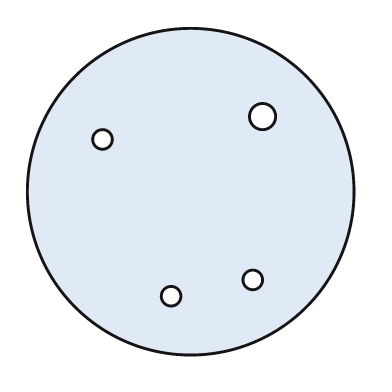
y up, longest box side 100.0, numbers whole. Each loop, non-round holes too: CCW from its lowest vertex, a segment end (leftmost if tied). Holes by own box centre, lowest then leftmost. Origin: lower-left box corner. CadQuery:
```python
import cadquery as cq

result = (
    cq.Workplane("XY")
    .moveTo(50.0, 50.0)
    .circle(50.0)
    .moveTo(44.0, 18.0)
    .circle(3.0)
    .moveTo(69.0, 23.0)
    .circle(3.0)
    .moveTo(23.0, 66.0)
    .circle(3.0)
    .moveTo(72.0, 73.0)
    .circle(4.0)
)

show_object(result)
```